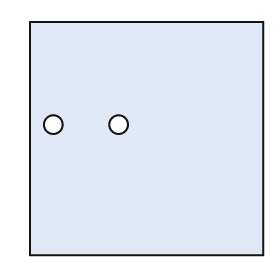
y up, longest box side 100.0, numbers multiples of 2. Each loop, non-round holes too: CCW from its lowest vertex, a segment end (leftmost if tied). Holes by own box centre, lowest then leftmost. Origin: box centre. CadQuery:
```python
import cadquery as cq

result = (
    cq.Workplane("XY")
    .moveTo(-50.0, -50.0)
    .lineTo(50.0, -50.0)
    .lineTo(50.0, 50.0)
    .lineTo(-50.0, 50.0)
    .close()
    .moveTo(-40.0, 6.0)
    .circle(4.0)
    .moveTo(-12.0, 6.0)
    .circle(4.0)
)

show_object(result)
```